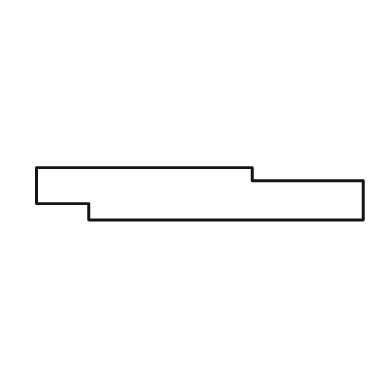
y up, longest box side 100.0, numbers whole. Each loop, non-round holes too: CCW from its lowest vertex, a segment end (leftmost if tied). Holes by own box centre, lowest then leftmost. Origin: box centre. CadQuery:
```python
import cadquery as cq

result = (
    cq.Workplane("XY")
    .moveTo(-34.0, -8.0)
    .lineTo(50.0, -8.0)
    .lineTo(50.0, 4.0)
    .lineTo(16.0, 4.0)
    .lineTo(16.0, 8.0)
    .lineTo(-50.0, 8.0)
    .lineTo(-50.0, -3.0)
    .lineTo(-34.0, -3.0)
    .close()
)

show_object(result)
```